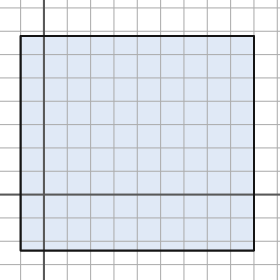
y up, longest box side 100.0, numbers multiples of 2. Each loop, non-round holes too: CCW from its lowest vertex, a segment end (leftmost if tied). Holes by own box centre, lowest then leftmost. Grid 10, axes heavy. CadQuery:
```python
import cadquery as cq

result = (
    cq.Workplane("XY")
    .moveTo(-10.0, -24.0)
    .lineTo(90.0, -24.0)
    .lineTo(90.0, 68.0)
    .lineTo(-10.0, 68.0)
    .close()
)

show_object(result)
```